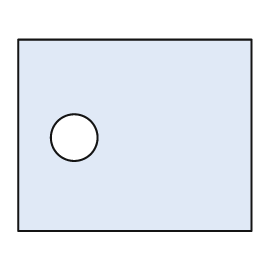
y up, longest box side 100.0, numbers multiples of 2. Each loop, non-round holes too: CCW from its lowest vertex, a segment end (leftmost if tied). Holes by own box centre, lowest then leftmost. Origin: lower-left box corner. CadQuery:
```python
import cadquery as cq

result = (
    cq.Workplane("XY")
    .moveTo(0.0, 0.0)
    .lineTo(100.0, 0.0)
    .lineTo(100.0, 82.0)
    .lineTo(0.0, 82.0)
    .close()
    .moveTo(24.0, 40.0)
    .circle(10.0)
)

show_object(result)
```